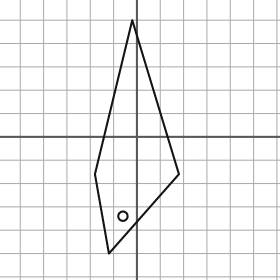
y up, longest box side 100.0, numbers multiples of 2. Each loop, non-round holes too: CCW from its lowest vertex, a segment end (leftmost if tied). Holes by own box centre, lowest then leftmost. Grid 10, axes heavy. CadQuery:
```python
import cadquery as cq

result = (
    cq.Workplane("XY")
    .moveTo(-12.0, -50.0)
    .lineTo(18.0, -16.0)
    .lineTo(-2.0, 50.0)
    .lineTo(-18.0, -16.0)
    .close()
    .moveTo(-6.0, -34.0)
    .circle(2.0)
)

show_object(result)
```